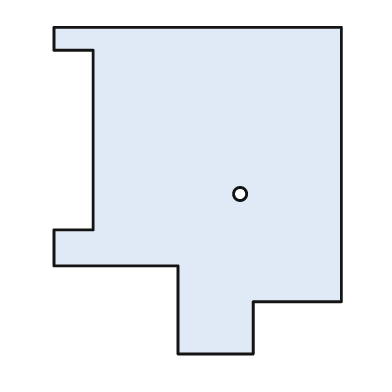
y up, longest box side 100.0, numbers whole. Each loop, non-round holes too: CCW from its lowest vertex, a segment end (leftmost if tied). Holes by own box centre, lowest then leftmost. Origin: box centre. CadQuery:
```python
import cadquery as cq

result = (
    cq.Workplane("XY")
    .moveTo(-6.0, -50.0)
    .lineTo(17.0, -50.0)
    .lineTo(17.0, -34.0)
    .lineTo(44.0, -34.0)
    .lineTo(44.0, 50.0)
    .lineTo(-44.0, 50.0)
    .lineTo(-44.0, 43.0)
    .lineTo(-32.0, 43.0)
    .lineTo(-32.0, -12.0)
    .lineTo(-44.0, -12.0)
    .lineTo(-44.0, -23.0)
    .lineTo(-6.0, -23.0)
    .close()
    .moveTo(13.0, -1.0)
    .circle(2.0)
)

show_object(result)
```